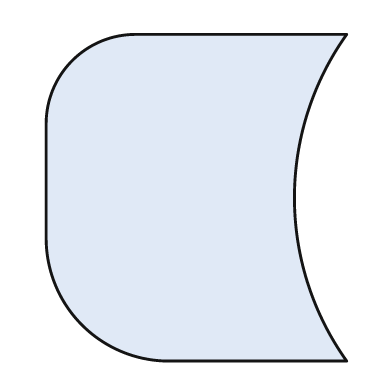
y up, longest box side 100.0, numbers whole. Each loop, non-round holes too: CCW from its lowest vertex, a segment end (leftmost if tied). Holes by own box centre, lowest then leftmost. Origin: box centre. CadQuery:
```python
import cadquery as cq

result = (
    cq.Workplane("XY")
    .moveTo(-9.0, -50.0)
    .lineTo(46.0, -50.0)
    .threePointArc((30.0, 0.0), (46.0, 50.0))
    .lineTo(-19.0, 50.0)
    .threePointArc((-38.0, 42.0), (-46.0, 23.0))
    .lineTo(-46.0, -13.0)
    .threePointArc((-35.0, -39.0), (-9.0, -50.0))
    .close()
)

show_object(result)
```